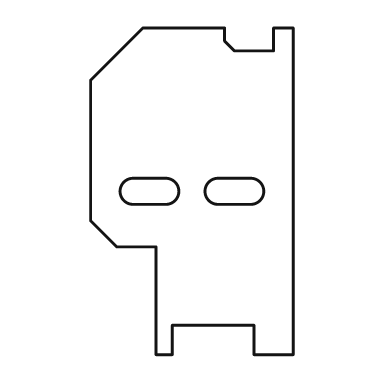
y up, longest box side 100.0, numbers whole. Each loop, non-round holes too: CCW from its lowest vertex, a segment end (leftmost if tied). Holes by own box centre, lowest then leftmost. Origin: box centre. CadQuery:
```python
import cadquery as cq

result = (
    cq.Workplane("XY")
    .moveTo(-11.0, -50.0)
    .lineTo(-6.0, -50.0)
    .lineTo(-6.0, -41.0)
    .lineTo(19.0, -41.0)
    .lineTo(19.0, -50.0)
    .lineTo(31.0, -50.0)
    .lineTo(31.0, 50.0)
    .lineTo(25.0, 50.0)
    .lineTo(25.0, 43.0)
    .lineTo(13.0, 43.0)
    .lineTo(10.0, 46.0)
    .lineTo(10.0, 50.0)
    .lineTo(-15.0, 50.0)
    .lineTo(-31.0, 34.0)
    .lineTo(-31.0, -9.0)
    .lineTo(-23.0, -17.0)
    .lineTo(-11.0, -17.0)
    .close()
    .moveTo(-18.0, -4.0)
    .lineTo(-8.0, -4.0)
    .threePointArc((-4.0, 0.0), (-8.0, 4.0))
    .lineTo(-18.0, 4.0)
    .threePointArc((-22.0, 0.0), (-18.0, -4.0))
    .close()
    .moveTo(8.0, -4.0)
    .lineTo(18.0, -4.0)
    .threePointArc((22.0, 0.0), (18.0, 4.0))
    .lineTo(8.0, 4.0)
    .threePointArc((4.0, 0.0), (8.0, -4.0))
    .close()
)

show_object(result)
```